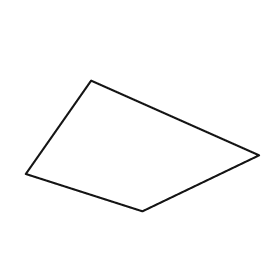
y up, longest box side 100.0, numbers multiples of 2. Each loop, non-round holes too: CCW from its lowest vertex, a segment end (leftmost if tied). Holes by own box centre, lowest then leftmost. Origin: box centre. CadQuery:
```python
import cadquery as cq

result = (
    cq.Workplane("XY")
    .moveTo(0.0, -28.0)
    .lineTo(50.0, -4.0)
    .lineTo(-22.0, 28.0)
    .lineTo(-50.0, -12.0)
    .close()
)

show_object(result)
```